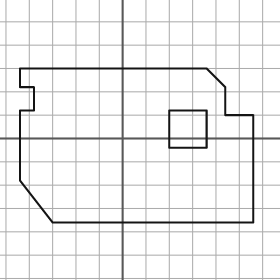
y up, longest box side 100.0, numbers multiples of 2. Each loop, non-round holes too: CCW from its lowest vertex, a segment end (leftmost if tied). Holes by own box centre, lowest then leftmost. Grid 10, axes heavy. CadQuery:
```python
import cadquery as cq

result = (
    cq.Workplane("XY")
    .moveTo(-30.0, -36.0)
    .lineTo(56.0, -36.0)
    .lineTo(56.0, 10.0)
    .lineTo(44.0, 10.0)
    .lineTo(44.0, 22.0)
    .lineTo(36.0, 30.0)
    .lineTo(-44.0, 30.0)
    .lineTo(-44.0, 22.0)
    .lineTo(-38.0, 22.0)
    .lineTo(-38.0, 12.0)
    .lineTo(-44.0, 12.0)
    .lineTo(-44.0, -18.0)
    .close()
    .moveTo(20.0, -4.0)
    .lineTo(36.0, -4.0)
    .lineTo(36.0, 12.0)
    .lineTo(20.0, 12.0)
    .close()
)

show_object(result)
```